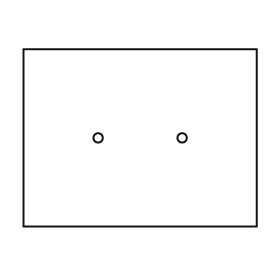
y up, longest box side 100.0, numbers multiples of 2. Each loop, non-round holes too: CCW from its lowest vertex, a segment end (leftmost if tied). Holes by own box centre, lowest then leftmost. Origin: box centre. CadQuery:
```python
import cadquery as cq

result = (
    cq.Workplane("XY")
    .moveTo(-50.0, -38.0)
    .lineTo(50.0, -38.0)
    .lineTo(50.0, 38.0)
    .lineTo(-50.0, 38.0)
    .close()
    .moveTo(-18.0, 0.0)
    .circle(2.0)
    .moveTo(18.0, 0.0)
    .circle(2.0)
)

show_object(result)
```